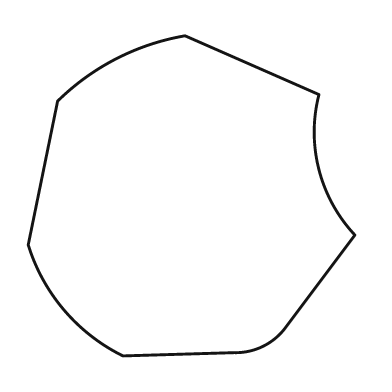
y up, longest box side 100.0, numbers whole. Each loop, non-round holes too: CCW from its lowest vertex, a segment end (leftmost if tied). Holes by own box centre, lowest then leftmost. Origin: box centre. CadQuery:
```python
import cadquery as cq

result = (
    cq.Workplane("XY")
    .moveTo(-21.0, -49.0)
    .lineTo(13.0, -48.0)
    .threePointArc((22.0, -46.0), (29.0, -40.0))
    .lineTo(50.0, -12.0)
    .threePointArc((39.0, 8.0), (39.0, 31.0))
    .lineTo(-2.0, 49.0)
    .threePointArc((-23.0, 42.0), (-41.0, 29.0))
    .lineTo(-50.0, -15.0)
    .threePointArc((-39.0, -35.0), (-21.0, -49.0))
    .close()
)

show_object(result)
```